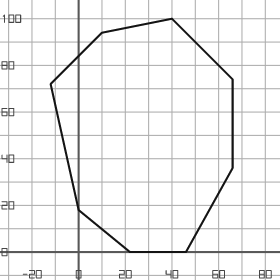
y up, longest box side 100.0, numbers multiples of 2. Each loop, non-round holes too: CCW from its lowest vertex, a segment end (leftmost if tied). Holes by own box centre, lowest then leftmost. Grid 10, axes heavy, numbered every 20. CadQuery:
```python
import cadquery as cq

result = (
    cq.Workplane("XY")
    .moveTo(22.0, 0.0)
    .lineTo(46.0, 0.0)
    .lineTo(66.0, 36.0)
    .lineTo(66.0, 74.0)
    .lineTo(40.0, 100.0)
    .lineTo(10.0, 94.0)
    .lineTo(-12.0, 72.0)
    .lineTo(0.0, 18.0)
    .close()
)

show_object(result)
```